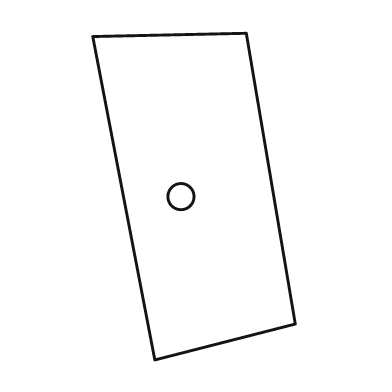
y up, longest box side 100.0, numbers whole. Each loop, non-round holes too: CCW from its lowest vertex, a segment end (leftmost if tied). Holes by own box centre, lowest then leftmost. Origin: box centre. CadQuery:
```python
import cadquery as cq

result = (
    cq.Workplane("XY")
    .moveTo(-12.0, -50.0)
    .lineTo(31.0, -39.0)
    .lineTo(16.0, 50.0)
    .lineTo(-31.0, 49.0)
    .close()
    .moveTo(-4.0, 0.0)
    .circle(4.0)
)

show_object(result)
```